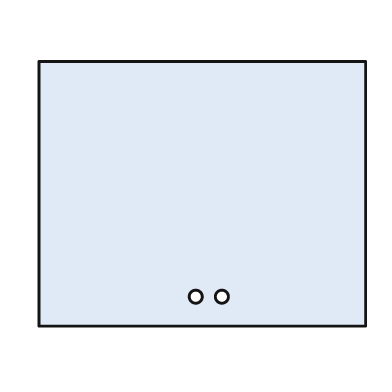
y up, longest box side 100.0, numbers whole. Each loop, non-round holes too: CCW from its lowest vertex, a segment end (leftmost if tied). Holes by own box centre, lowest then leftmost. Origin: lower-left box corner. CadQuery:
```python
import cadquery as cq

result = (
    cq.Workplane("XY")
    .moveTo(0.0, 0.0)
    .lineTo(100.0, 0.0)
    .lineTo(100.0, 81.0)
    .lineTo(0.0, 81.0)
    .close()
    .moveTo(48.0, 9.0)
    .circle(2.0)
    .moveTo(56.0, 9.0)
    .circle(2.0)
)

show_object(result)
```